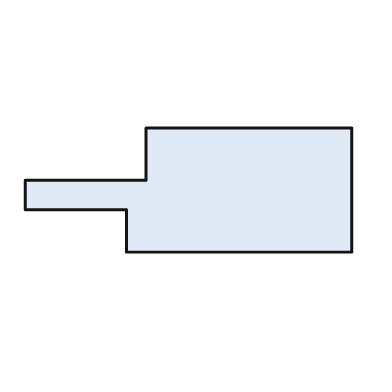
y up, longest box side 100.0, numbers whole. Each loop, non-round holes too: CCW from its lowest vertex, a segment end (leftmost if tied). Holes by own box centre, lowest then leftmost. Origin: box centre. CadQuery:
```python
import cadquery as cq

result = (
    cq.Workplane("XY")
    .moveTo(-19.0, -19.0)
    .lineTo(50.0, -19.0)
    .lineTo(50.0, 19.0)
    .lineTo(-13.0, 19.0)
    .lineTo(-13.0, 3.0)
    .lineTo(-50.0, 3.0)
    .lineTo(-50.0, -6.0)
    .lineTo(-19.0, -6.0)
    .close()
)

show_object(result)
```